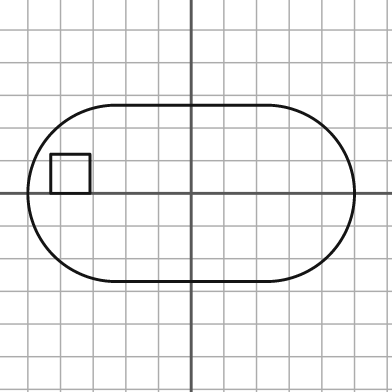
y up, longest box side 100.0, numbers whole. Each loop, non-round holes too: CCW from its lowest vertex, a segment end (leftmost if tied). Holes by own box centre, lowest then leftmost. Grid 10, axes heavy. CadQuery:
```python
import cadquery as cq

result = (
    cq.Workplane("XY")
    .moveTo(-23.0, -27.0)
    .lineTo(23.0, -27.0)
    .threePointArc((50.0, 0.0), (23.0, 27.0))
    .lineTo(-23.0, 27.0)
    .threePointArc((-50.0, 0.0), (-23.0, -27.0))
    .close()
    .moveTo(-43.0, 0.0)
    .lineTo(-31.0, 0.0)
    .lineTo(-31.0, 12.0)
    .lineTo(-43.0, 12.0)
    .close()
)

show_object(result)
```